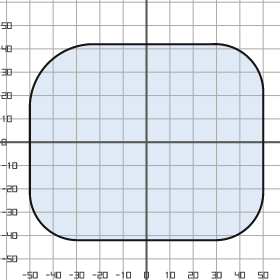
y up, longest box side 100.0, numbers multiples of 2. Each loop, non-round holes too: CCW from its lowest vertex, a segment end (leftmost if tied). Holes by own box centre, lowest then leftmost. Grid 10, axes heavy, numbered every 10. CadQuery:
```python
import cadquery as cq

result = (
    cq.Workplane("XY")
    .moveTo(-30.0, -42.0)
    .lineTo(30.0, -42.0)
    .threePointArc((44.0, -36.0), (50.0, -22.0))
    .lineTo(50.0, 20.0)
    .threePointArc((44.0, 36.0), (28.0, 42.0))
    .lineTo(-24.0, 42.0)
    .threePointArc((-42.0, 34.0), (-50.0, 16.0))
    .lineTo(-50.0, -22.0)
    .threePointArc((-44.0, -36.0), (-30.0, -42.0))
    .close()
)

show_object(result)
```